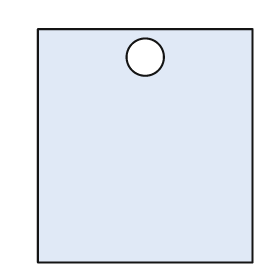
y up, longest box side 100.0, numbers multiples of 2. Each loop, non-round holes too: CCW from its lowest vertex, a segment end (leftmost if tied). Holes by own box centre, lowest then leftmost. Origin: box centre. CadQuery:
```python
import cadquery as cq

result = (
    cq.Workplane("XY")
    .moveTo(-46.0, -50.0)
    .lineTo(46.0, -50.0)
    .lineTo(46.0, 50.0)
    .lineTo(-46.0, 50.0)
    .close()
    .moveTo(0.0, 38.0)
    .circle(8.0)
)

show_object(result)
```